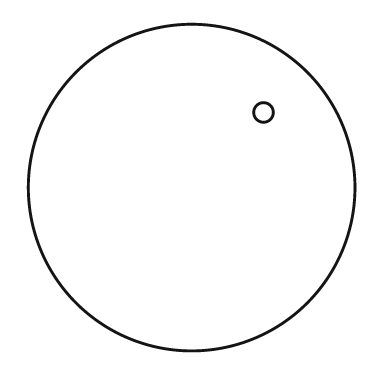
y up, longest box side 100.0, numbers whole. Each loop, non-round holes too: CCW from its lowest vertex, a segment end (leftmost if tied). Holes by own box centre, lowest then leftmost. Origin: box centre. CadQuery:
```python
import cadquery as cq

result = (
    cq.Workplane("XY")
    .moveTo(0.0, 0.0)
    .circle(50.0)
    .moveTo(22.0, 23.0)
    .circle(3.0)
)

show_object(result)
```